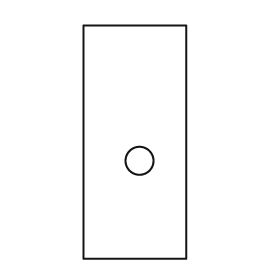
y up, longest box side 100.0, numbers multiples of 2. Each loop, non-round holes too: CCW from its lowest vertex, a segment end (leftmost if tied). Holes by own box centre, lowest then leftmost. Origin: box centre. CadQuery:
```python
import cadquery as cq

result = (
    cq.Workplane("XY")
    .moveTo(-22.0, -50.0)
    .lineTo(22.0, -50.0)
    .lineTo(22.0, 50.0)
    .lineTo(-22.0, 50.0)
    .close()
    .moveTo(2.0, -8.0)
    .circle(6.0)
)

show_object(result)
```